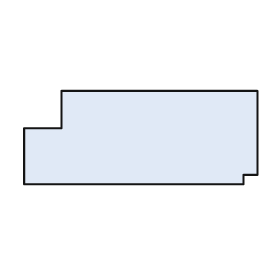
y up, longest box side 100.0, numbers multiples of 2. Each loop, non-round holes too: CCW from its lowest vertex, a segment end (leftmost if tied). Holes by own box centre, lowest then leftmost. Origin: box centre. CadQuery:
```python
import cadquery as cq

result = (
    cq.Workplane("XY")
    .moveTo(-50.0, -20.0)
    .lineTo(44.0, -20.0)
    .lineTo(44.0, -16.0)
    .lineTo(50.0, -16.0)
    .lineTo(50.0, 20.0)
    .lineTo(-34.0, 20.0)
    .lineTo(-34.0, 4.0)
    .lineTo(-50.0, 4.0)
    .close()
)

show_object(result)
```